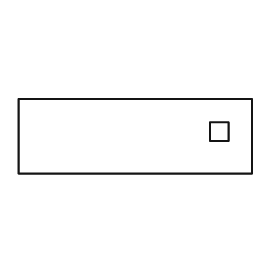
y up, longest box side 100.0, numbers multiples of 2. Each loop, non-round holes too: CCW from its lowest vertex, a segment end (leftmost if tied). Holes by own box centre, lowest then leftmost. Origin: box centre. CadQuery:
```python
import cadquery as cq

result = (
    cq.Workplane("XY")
    .moveTo(-50.0, -16.0)
    .lineTo(50.0, -16.0)
    .lineTo(50.0, 16.0)
    .lineTo(-50.0, 16.0)
    .close()
    .moveTo(32.0, -2.0)
    .lineTo(40.0, -2.0)
    .lineTo(40.0, 6.0)
    .lineTo(32.0, 6.0)
    .close()
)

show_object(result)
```